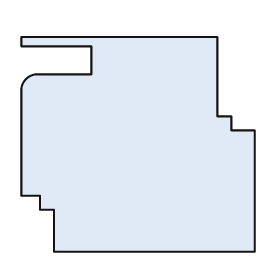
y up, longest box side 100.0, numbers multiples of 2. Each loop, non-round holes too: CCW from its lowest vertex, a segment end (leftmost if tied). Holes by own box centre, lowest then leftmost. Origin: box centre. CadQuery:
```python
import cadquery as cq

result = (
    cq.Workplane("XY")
    .moveTo(-36.0, -46.0)
    .lineTo(50.0, -46.0)
    .lineTo(50.0, 6.0)
    .lineTo(40.0, 6.0)
    .lineTo(40.0, 12.0)
    .lineTo(34.0, 12.0)
    .lineTo(34.0, 46.0)
    .lineTo(-50.0, 46.0)
    .lineTo(-50.0, 42.0)
    .lineTo(-20.0, 42.0)
    .lineTo(-20.0, 30.0)
    .lineTo(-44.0, 30.0)
    .threePointArc((-48.0, 28.0), (-50.0, 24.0))
    .lineTo(-50.0, -22.0)
    .lineTo(-42.0, -22.0)
    .lineTo(-42.0, -28.0)
    .lineTo(-36.0, -28.0)
    .close()
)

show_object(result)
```